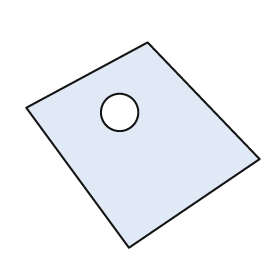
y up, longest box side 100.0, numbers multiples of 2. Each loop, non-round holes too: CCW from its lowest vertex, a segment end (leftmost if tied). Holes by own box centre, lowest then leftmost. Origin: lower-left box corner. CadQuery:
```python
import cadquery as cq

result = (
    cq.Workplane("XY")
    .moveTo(44.0, 0.0)
    .lineTo(100.0, 38.0)
    .lineTo(52.0, 88.0)
    .lineTo(0.0, 60.0)
    .close()
    .moveTo(40.0, 58.0)
    .circle(8.0)
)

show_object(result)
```